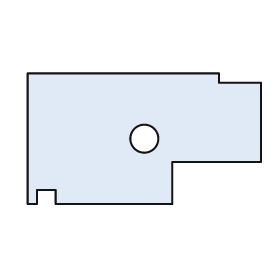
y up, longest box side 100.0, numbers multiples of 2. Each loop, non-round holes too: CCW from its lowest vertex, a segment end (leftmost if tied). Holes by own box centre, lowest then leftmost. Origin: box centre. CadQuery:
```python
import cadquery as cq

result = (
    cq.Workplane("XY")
    .moveTo(-50.0, -28.0)
    .lineTo(-46.0, -28.0)
    .lineTo(-46.0, -22.0)
    .lineTo(-38.0, -22.0)
    .lineTo(-38.0, -28.0)
    .lineTo(12.0, -28.0)
    .lineTo(12.0, -10.0)
    .lineTo(50.0, -10.0)
    .lineTo(50.0, 24.0)
    .lineTo(32.0, 24.0)
    .lineTo(32.0, 28.0)
    .lineTo(-50.0, 28.0)
    .close()
    .moveTo(0.0, 0.0)
    .circle(6.0)
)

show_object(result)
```